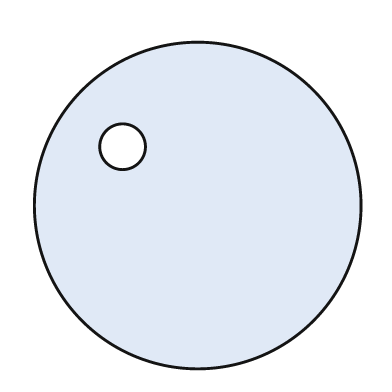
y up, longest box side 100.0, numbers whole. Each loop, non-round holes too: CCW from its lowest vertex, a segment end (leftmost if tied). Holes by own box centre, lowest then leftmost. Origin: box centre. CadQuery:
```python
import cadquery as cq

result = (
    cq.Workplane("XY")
    .moveTo(0.0, 0.0)
    .circle(50.0)
    .moveTo(-23.0, 18.0)
    .circle(7.0)
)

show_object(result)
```